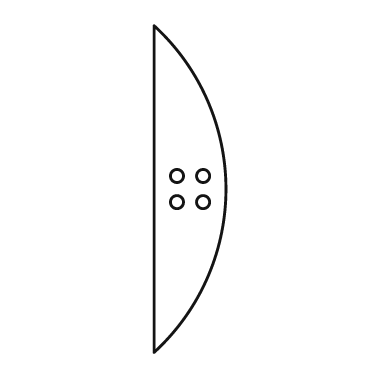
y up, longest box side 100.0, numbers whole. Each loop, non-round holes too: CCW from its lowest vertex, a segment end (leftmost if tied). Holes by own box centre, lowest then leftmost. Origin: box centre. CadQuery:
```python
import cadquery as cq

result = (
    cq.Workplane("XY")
    .moveTo(-11.0, -50.0)
    .threePointArc((11.0, 0.0), (-11.0, 50.0))
    .close()
    .moveTo(-4.0, -4.0)
    .circle(2.0)
    .moveTo(4.0, -4.0)
    .circle(2.0)
    .moveTo(-4.0, 4.0)
    .circle(2.0)
    .moveTo(4.0, 4.0)
    .circle(2.0)
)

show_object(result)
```